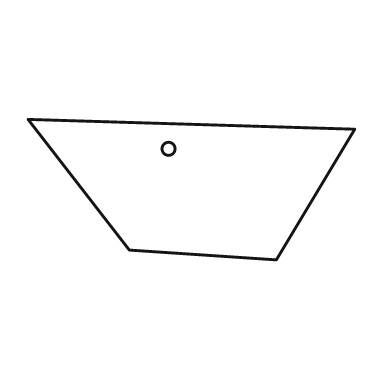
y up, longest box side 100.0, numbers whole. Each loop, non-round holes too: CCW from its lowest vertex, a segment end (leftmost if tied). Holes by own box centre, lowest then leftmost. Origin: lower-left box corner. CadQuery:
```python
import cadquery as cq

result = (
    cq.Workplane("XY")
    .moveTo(76.0, 0.0)
    .lineTo(100.0, 40.0)
    .lineTo(0.0, 43.0)
    .lineTo(31.0, 3.0)
    .close()
    .moveTo(43.0, 34.0)
    .circle(2.0)
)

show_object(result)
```